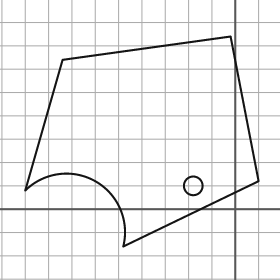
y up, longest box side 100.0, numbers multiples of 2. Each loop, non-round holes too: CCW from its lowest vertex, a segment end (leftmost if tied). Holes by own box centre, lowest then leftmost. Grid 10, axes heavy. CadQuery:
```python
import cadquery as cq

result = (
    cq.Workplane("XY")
    .moveTo(-48.0, -16.0)
    .lineTo(10.0, 12.0)
    .lineTo(-2.0, 74.0)
    .lineTo(-74.0, 64.0)
    .lineTo(-90.0, 8.0)
    .threePointArc((-60.0, 12.0), (-48.0, -16.0))
    .close()
    .moveTo(-18.0, 10.0)
    .circle(4.0)
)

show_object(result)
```